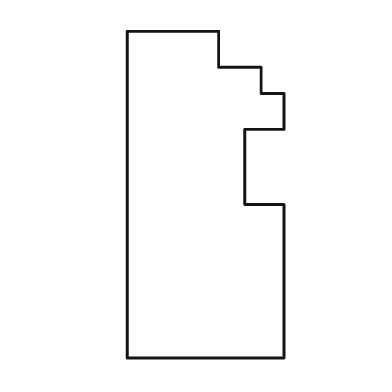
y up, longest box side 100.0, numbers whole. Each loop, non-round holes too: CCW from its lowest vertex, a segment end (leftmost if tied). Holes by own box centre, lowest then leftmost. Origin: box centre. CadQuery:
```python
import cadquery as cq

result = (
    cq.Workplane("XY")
    .moveTo(-24.0, -50.0)
    .lineTo(24.0, -50.0)
    .lineTo(24.0, -3.0)
    .lineTo(12.0, -3.0)
    .lineTo(12.0, 20.0)
    .lineTo(24.0, 20.0)
    .lineTo(24.0, 31.0)
    .lineTo(17.0, 31.0)
    .lineTo(17.0, 39.0)
    .lineTo(4.0, 39.0)
    .lineTo(4.0, 50.0)
    .lineTo(-24.0, 50.0)
    .close()
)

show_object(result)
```